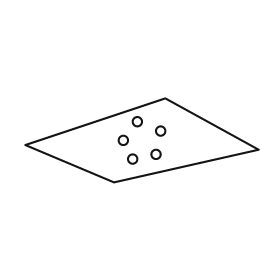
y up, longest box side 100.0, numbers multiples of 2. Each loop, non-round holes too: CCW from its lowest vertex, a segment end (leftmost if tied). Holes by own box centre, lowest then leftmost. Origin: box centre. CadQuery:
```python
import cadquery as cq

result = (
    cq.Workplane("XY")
    .moveTo(-12.0, -18.0)
    .lineTo(50.0, -4.0)
    .lineTo(10.0, 18.0)
    .lineTo(-50.0, -2.0)
    .close()
    .moveTo(-4.0, -8.0)
    .circle(2.0)
    .moveTo(6.0, -6.0)
    .circle(2.0)
    .moveTo(-8.0, 0.0)
    .circle(2.0)
    .moveTo(8.0, 4.0)
    .circle(2.0)
    .moveTo(-2.0, 8.0)
    .circle(2.0)
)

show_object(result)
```